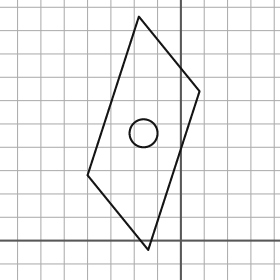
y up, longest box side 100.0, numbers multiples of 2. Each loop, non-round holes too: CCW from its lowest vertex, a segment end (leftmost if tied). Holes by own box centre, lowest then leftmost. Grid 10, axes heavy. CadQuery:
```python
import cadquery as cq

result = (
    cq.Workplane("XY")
    .moveTo(-14.0, -4.0)
    .lineTo(8.0, 64.0)
    .lineTo(-18.0, 96.0)
    .lineTo(-40.0, 28.0)
    .close()
    .moveTo(-16.0, 46.0)
    .circle(6.0)
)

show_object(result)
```